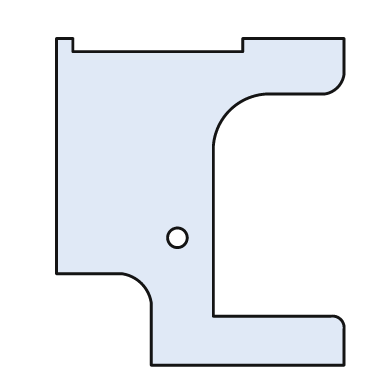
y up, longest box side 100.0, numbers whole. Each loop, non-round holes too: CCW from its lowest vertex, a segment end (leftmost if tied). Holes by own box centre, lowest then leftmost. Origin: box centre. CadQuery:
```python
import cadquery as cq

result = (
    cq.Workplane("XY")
    .moveTo(-15.0, -50.0)
    .lineTo(44.0, -50.0)
    .lineTo(44.0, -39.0)
    .threePointArc((43.0, -36.0), (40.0, -35.0))
    .lineTo(4.0, -35.0)
    .lineTo(4.0, 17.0)
    .threePointArc((9.0, 28.0), (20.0, 33.0))
    .lineTo(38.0, 33.0)
    .threePointArc((42.0, 35.0), (44.0, 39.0))
    .lineTo(44.0, 50.0)
    .lineTo(13.0, 50.0)
    .lineTo(13.0, 46.0)
    .lineTo(-39.0, 46.0)
    .lineTo(-39.0, 50.0)
    .lineTo(-44.0, 50.0)
    .lineTo(-44.0, -22.0)
    .lineTo(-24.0, -22.0)
    .threePointArc((-18.0, -25.0), (-15.0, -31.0))
    .close()
    .moveTo(-7.0, -11.0)
    .circle(3.0)
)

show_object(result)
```